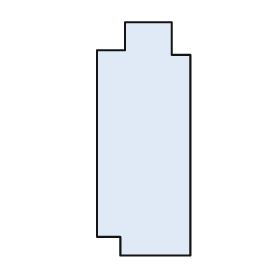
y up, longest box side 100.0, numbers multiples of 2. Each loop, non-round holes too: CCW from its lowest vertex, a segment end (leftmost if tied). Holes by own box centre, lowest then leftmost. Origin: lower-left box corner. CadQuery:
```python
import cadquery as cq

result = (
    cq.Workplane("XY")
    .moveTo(10.0, 0.0)
    .lineTo(40.0, 0.0)
    .lineTo(40.0, 86.0)
    .lineTo(32.0, 86.0)
    .lineTo(32.0, 100.0)
    .lineTo(12.0, 100.0)
    .lineTo(12.0, 88.0)
    .lineTo(0.0, 88.0)
    .lineTo(0.0, 8.0)
    .lineTo(10.0, 8.0)
    .close()
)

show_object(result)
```